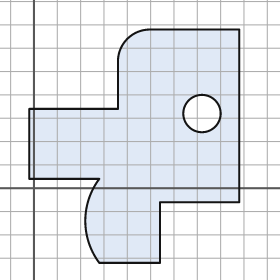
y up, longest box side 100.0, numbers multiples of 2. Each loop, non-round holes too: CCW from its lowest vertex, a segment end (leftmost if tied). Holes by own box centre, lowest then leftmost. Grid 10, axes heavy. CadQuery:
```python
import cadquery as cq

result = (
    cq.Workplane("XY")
    .moveTo(28.0, -32.0)
    .lineTo(54.0, -32.0)
    .lineTo(54.0, -6.0)
    .lineTo(88.0, -6.0)
    .lineTo(88.0, 68.0)
    .lineTo(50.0, 68.0)
    .threePointArc((40.0, 64.0), (36.0, 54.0))
    .lineTo(36.0, 34.0)
    .lineTo(-2.0, 34.0)
    .lineTo(-2.0, 4.0)
    .lineTo(28.0, 4.0)
    .threePointArc((22.0, -14.0), (28.0, -32.0))
    .close()
    .moveTo(72.0, 32.0)
    .circle(8.0)
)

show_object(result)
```